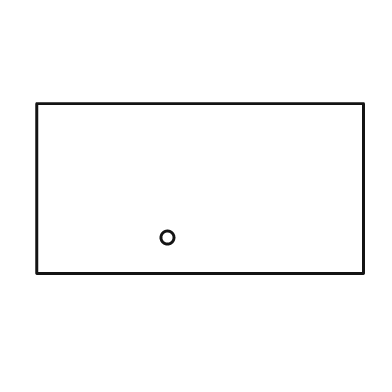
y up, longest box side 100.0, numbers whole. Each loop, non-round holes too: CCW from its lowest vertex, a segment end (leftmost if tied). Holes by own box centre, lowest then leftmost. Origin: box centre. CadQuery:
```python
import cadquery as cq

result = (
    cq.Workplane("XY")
    .moveTo(-50.0, -26.0)
    .lineTo(50.0, -26.0)
    .lineTo(50.0, 26.0)
    .lineTo(-50.0, 26.0)
    .close()
    .moveTo(-10.0, -15.0)
    .circle(2.0)
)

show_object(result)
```